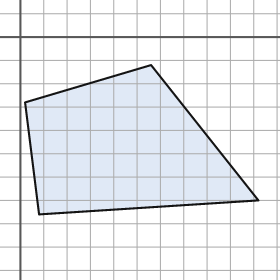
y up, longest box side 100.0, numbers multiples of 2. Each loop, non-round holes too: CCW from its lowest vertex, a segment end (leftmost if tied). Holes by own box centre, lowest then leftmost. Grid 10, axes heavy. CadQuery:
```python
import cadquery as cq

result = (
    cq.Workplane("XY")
    .moveTo(8.0, -76.0)
    .lineTo(102.0, -70.0)
    .lineTo(56.0, -12.0)
    .lineTo(2.0, -28.0)
    .close()
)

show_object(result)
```